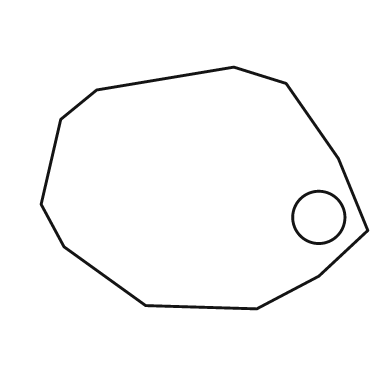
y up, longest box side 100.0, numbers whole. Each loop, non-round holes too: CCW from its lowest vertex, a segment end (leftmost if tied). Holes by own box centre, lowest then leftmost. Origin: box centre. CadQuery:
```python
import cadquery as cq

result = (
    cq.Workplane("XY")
    .moveTo(16.0, -37.0)
    .lineTo(35.0, -27.0)
    .lineTo(50.0, -13.0)
    .lineTo(41.0, 9.0)
    .lineTo(25.0, 32.0)
    .lineTo(9.0, 37.0)
    .lineTo(-33.0, 30.0)
    .lineTo(-44.0, 21.0)
    .lineTo(-50.0, -5.0)
    .lineTo(-43.0, -18.0)
    .lineTo(-18.0, -36.0)
    .close()
    .moveTo(35.0, -9.0)
    .circle(8.0)
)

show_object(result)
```